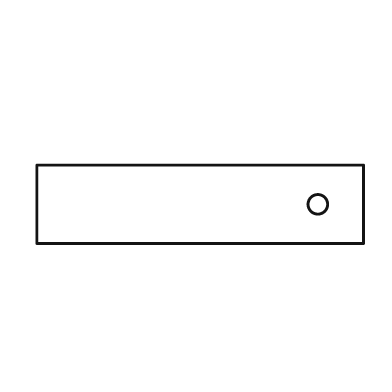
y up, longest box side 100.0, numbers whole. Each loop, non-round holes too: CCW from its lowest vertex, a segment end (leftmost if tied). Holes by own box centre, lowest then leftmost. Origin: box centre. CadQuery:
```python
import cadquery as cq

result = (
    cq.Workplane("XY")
    .moveTo(-50.0, -12.0)
    .lineTo(50.0, -12.0)
    .lineTo(50.0, 12.0)
    .lineTo(-50.0, 12.0)
    .close()
    .moveTo(36.0, 0.0)
    .circle(3.0)
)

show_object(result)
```